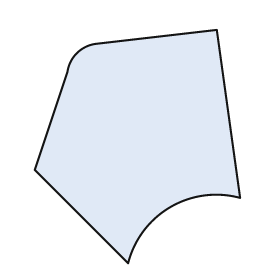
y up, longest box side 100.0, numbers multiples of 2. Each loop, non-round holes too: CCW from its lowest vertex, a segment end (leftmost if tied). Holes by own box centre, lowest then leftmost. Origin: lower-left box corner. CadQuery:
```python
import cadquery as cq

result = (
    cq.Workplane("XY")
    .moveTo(40.0, 0.0)
    .threePointArc((58.0, 24.0), (88.0, 28.0))
    .lineTo(78.0, 100.0)
    .lineTo(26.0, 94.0)
    .threePointArc((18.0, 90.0), (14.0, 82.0))
    .lineTo(0.0, 40.0)
    .close()
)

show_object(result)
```